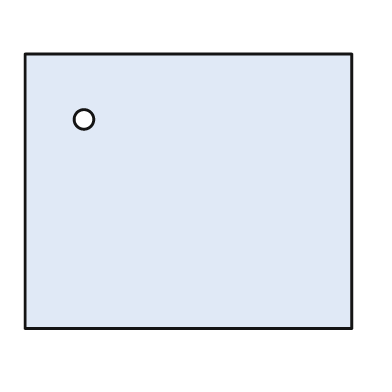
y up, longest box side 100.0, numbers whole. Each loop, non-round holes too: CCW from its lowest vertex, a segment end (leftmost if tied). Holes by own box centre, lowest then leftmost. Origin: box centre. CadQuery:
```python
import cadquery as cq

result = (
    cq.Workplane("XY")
    .moveTo(-50.0, -42.0)
    .lineTo(50.0, -42.0)
    .lineTo(50.0, 42.0)
    .lineTo(-50.0, 42.0)
    .close()
    .moveTo(-32.0, 22.0)
    .circle(3.0)
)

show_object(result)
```